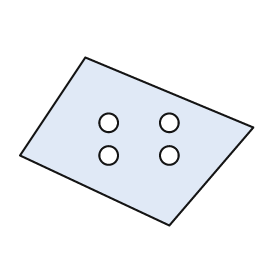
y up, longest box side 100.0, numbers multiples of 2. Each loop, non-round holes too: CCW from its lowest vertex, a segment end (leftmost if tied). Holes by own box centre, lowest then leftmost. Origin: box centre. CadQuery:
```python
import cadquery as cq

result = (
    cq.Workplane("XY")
    .moveTo(14.0, -36.0)
    .lineTo(50.0, 6.0)
    .lineTo(-22.0, 36.0)
    .lineTo(-50.0, -6.0)
    .close()
    .moveTo(-12.0, -6.0)
    .circle(4.0)
    .moveTo(14.0, -6.0)
    .circle(4.0)
    .moveTo(-12.0, 8.0)
    .circle(4.0)
    .moveTo(14.0, 8.0)
    .circle(4.0)
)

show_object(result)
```